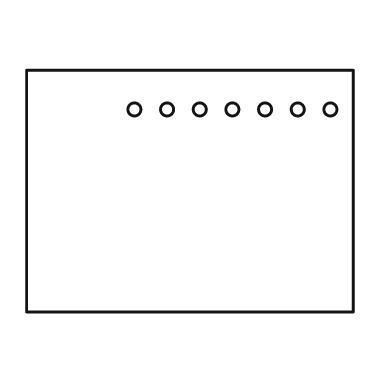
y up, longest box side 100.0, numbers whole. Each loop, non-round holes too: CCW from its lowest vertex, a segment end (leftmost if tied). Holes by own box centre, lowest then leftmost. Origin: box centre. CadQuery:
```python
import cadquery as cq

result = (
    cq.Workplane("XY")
    .moveTo(-50.0, -37.0)
    .lineTo(50.0, -37.0)
    .lineTo(50.0, 37.0)
    .lineTo(-50.0, 37.0)
    .close()
    .moveTo(-17.0, 25.0)
    .circle(2.0)
    .moveTo(-7.0, 25.0)
    .circle(2.0)
    .moveTo(3.0, 25.0)
    .circle(2.0)
    .moveTo(13.0, 25.0)
    .circle(2.0)
    .moveTo(23.0, 25.0)
    .circle(2.0)
    .moveTo(33.0, 25.0)
    .circle(2.0)
    .moveTo(43.0, 25.0)
    .circle(2.0)
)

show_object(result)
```